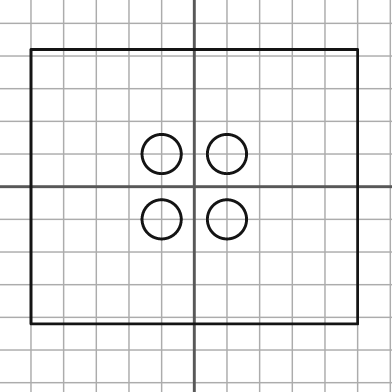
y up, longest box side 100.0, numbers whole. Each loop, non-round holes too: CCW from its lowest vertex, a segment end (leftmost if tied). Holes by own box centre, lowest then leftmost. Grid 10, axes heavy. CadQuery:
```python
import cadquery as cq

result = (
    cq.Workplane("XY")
    .moveTo(-50.0, -42.0)
    .lineTo(50.0, -42.0)
    .lineTo(50.0, 42.0)
    .lineTo(-50.0, 42.0)
    .close()
    .moveTo(-10.0, -10.0)
    .circle(6.0)
    .moveTo(10.0, -10.0)
    .circle(6.0)
    .moveTo(-10.0, 10.0)
    .circle(6.0)
    .moveTo(10.0, 10.0)
    .circle(6.0)
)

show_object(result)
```